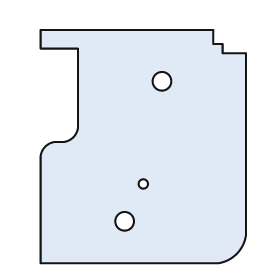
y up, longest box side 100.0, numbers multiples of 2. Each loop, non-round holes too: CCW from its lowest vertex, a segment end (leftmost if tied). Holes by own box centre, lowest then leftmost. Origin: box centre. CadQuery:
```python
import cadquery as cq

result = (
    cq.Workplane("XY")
    .moveTo(-44.0, -50.0)
    .lineTo(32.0, -50.0)
    .threePointArc((40.0, -46.0), (44.0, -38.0))
    .lineTo(44.0, 40.0)
    .lineTo(34.0, 40.0)
    .lineTo(34.0, 44.0)
    .lineTo(30.0, 44.0)
    .lineTo(30.0, 50.0)
    .lineTo(-44.0, 50.0)
    .lineTo(-44.0, 42.0)
    .lineTo(-28.0, 42.0)
    .lineTo(-28.0, 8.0)
    .threePointArc((-30.0, 4.0), (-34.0, 2.0))
    .lineTo(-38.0, 2.0)
    .threePointArc((-42.0, 0.0), (-44.0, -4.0))
    .close()
    .moveTo(-8.0, -32.0)
    .circle(4.0)
    .moveTo(0.0, -16.0)
    .circle(2.0)
    .moveTo(8.0, 28.0)
    .circle(4.0)
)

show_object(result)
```